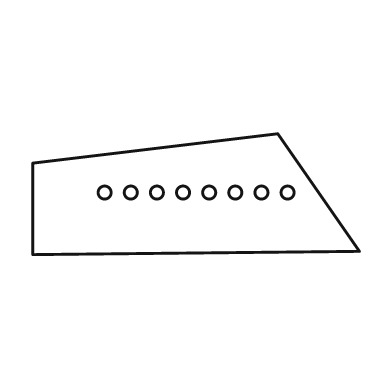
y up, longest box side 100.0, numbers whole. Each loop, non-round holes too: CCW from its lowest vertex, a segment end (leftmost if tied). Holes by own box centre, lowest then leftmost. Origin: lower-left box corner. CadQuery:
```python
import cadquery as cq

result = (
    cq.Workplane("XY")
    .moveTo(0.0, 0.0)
    .lineTo(100.0, 1.0)
    .lineTo(75.0, 37.0)
    .lineTo(0.0, 28.0)
    .close()
    .moveTo(22.0, 19.0)
    .circle(2.0)
    .moveTo(30.0, 19.0)
    .circle(2.0)
    .moveTo(38.0, 19.0)
    .circle(2.0)
    .moveTo(46.0, 19.0)
    .circle(2.0)
    .moveTo(54.0, 19.0)
    .circle(2.0)
    .moveTo(62.0, 19.0)
    .circle(2.0)
    .moveTo(70.0, 19.0)
    .circle(2.0)
    .moveTo(78.0, 19.0)
    .circle(2.0)
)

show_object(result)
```